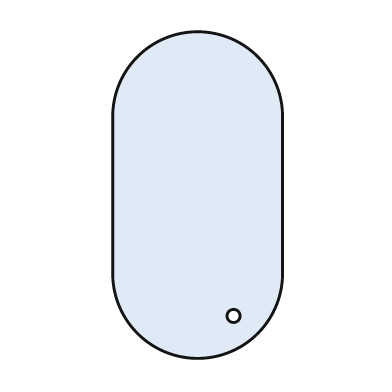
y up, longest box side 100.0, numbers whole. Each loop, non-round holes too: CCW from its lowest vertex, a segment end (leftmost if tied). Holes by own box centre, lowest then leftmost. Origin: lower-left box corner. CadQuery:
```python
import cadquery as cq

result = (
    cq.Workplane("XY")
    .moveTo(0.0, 26.0)
    .threePointArc((26.0, 0.0), (52.0, 26.0))
    .lineTo(52.0, 74.0)
    .threePointArc((26.0, 100.0), (0.0, 74.0))
    .close()
    .moveTo(37.0, 13.0)
    .circle(2.0)
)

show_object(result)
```